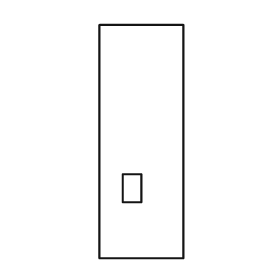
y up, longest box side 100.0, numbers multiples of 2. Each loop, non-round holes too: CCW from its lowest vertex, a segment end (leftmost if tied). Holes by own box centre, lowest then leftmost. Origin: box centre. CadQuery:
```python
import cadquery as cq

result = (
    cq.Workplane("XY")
    .moveTo(-18.0, -50.0)
    .lineTo(18.0, -50.0)
    .lineTo(18.0, 50.0)
    .lineTo(-18.0, 50.0)
    .close()
    .moveTo(-8.0, -26.0)
    .lineTo(0.0, -26.0)
    .lineTo(0.0, -14.0)
    .lineTo(-8.0, -14.0)
    .close()
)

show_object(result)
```